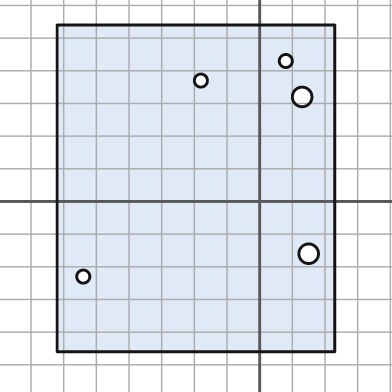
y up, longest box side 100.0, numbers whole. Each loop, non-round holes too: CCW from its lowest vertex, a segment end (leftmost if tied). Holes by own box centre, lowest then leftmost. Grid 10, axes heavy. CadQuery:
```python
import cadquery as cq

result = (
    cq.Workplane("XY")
    .moveTo(-62.0, -46.0)
    .lineTo(23.0, -46.0)
    .lineTo(23.0, 54.0)
    .lineTo(-62.0, 54.0)
    .close()
    .moveTo(-54.0, -23.0)
    .circle(2.0)
    .moveTo(15.0, -16.0)
    .circle(3.0)
    .moveTo(13.0, 32.0)
    .circle(3.0)
    .moveTo(-18.0, 37.0)
    .circle(2.0)
    .moveTo(8.0, 43.0)
    .circle(2.0)
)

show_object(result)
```